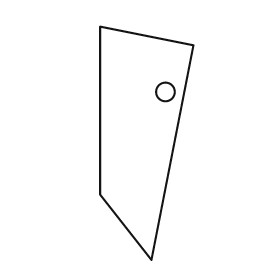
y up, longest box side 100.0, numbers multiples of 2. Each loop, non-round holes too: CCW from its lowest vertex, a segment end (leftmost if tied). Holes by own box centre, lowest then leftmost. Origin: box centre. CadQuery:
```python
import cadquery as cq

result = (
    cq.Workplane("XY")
    .moveTo(2.0, -50.0)
    .lineTo(20.0, 42.0)
    .lineTo(-20.0, 50.0)
    .lineTo(-20.0, -22.0)
    .close()
    .moveTo(8.0, 22.0)
    .circle(4.0)
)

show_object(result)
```